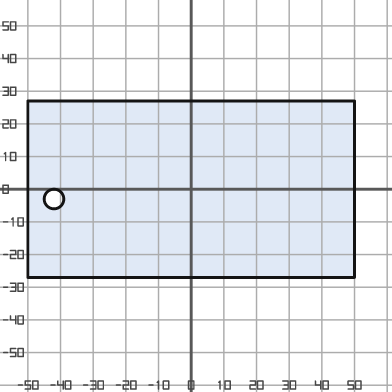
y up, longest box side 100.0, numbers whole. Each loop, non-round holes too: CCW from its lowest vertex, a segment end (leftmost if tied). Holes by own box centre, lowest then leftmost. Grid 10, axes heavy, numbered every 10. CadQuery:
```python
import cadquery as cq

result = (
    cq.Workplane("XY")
    .moveTo(-50.0, -27.0)
    .lineTo(50.0, -27.0)
    .lineTo(50.0, 27.0)
    .lineTo(-50.0, 27.0)
    .close()
    .moveTo(-42.0, -3.0)
    .circle(3.0)
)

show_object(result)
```